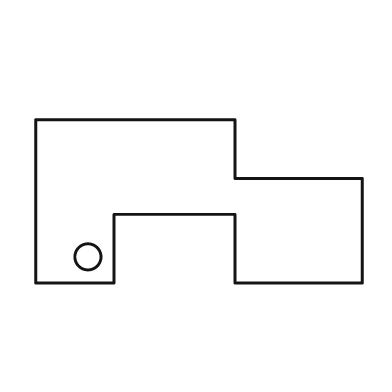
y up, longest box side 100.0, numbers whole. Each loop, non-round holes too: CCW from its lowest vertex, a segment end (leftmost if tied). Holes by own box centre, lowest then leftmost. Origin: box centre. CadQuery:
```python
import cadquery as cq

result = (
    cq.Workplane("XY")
    .moveTo(-50.0, -25.0)
    .lineTo(-26.0, -25.0)
    .lineTo(-26.0, -4.0)
    .lineTo(11.0, -4.0)
    .lineTo(11.0, -25.0)
    .lineTo(50.0, -25.0)
    .lineTo(50.0, 7.0)
    .lineTo(11.0, 7.0)
    .lineTo(11.0, 25.0)
    .lineTo(-50.0, 25.0)
    .close()
    .moveTo(-34.0, -17.0)
    .circle(4.0)
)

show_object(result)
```